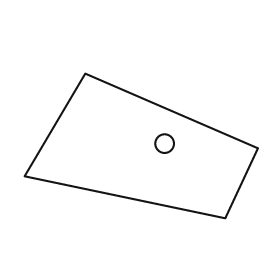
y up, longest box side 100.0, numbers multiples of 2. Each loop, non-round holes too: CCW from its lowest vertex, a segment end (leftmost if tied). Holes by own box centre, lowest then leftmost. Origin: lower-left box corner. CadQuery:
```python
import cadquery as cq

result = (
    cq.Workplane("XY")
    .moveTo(86.0, 0.0)
    .lineTo(100.0, 30.0)
    .lineTo(26.0, 62.0)
    .lineTo(0.0, 18.0)
    .close()
    .moveTo(60.0, 32.0)
    .circle(4.0)
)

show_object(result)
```